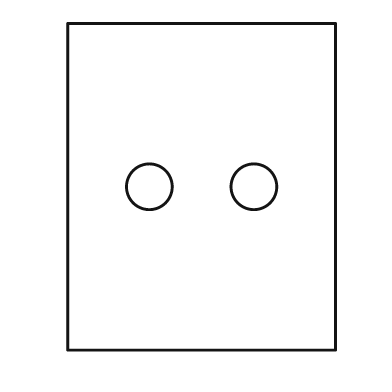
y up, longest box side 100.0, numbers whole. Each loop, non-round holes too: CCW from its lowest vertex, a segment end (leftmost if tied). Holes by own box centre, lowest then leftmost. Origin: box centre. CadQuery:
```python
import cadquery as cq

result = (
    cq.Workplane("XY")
    .moveTo(-41.0, -50.0)
    .lineTo(41.0, -50.0)
    .lineTo(41.0, 50.0)
    .lineTo(-41.0, 50.0)
    .close()
    .moveTo(-16.0, 0.0)
    .circle(7.0)
    .moveTo(16.0, 0.0)
    .circle(7.0)
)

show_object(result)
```